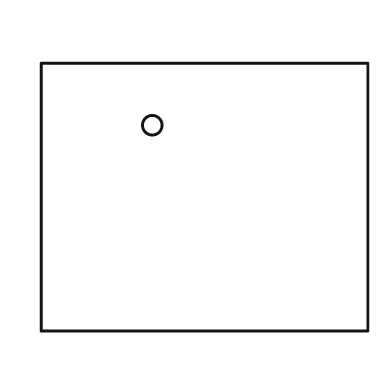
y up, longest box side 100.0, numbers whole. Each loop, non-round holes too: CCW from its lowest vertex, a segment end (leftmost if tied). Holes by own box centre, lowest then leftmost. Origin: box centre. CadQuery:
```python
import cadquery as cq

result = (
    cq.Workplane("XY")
    .moveTo(-50.0, -41.0)
    .lineTo(50.0, -41.0)
    .lineTo(50.0, 41.0)
    .lineTo(-50.0, 41.0)
    .close()
    .moveTo(-16.0, 22.0)
    .circle(3.0)
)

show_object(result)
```